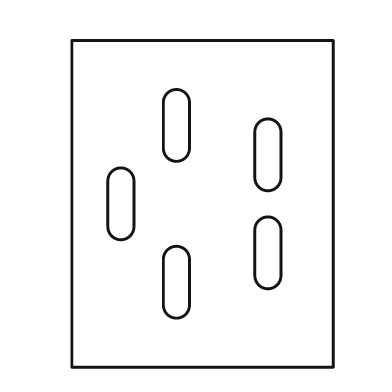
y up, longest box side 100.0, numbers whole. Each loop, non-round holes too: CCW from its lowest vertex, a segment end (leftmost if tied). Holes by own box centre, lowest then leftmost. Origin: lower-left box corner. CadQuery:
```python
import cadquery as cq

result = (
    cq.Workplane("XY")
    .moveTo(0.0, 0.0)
    .lineTo(80.0, 0.0)
    .lineTo(80.0, 100.0)
    .lineTo(0.0, 100.0)
    .close()
    .moveTo(28.0, 19.0)
    .threePointArc((32.0, 15.0), (36.0, 19.0))
    .lineTo(36.0, 33.0)
    .threePointArc((32.0, 37.0), (28.0, 33.0))
    .close()
    .moveTo(56.0, 28.0)
    .threePointArc((60.0, 24.0), (64.0, 28.0))
    .lineTo(64.0, 42.0)
    .threePointArc((60.0, 46.0), (56.0, 42.0))
    .close()
    .moveTo(11.0, 43.0)
    .threePointArc((15.0, 39.0), (19.0, 43.0))
    .lineTo(19.0, 57.0)
    .threePointArc((15.0, 61.0), (11.0, 57.0))
    .close()
    .moveTo(56.0, 58.0)
    .threePointArc((60.0, 54.0), (64.0, 58.0))
    .lineTo(64.0, 72.0)
    .threePointArc((60.0, 76.0), (56.0, 72.0))
    .close()
    .moveTo(28.0, 67.0)
    .threePointArc((32.0, 63.0), (36.0, 67.0))
    .lineTo(36.0, 81.0)
    .threePointArc((32.0, 85.0), (28.0, 81.0))
    .close()
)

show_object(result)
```